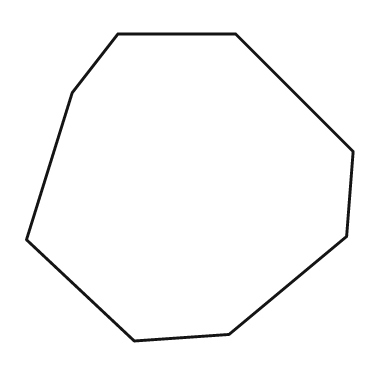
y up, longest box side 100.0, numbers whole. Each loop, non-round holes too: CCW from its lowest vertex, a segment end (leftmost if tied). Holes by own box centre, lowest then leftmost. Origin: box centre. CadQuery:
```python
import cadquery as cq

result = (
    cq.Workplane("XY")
    .moveTo(-17.0, -47.0)
    .lineTo(12.0, -45.0)
    .lineTo(48.0, -15.0)
    .lineTo(50.0, 11.0)
    .lineTo(14.0, 47.0)
    .lineTo(-22.0, 47.0)
    .lineTo(-36.0, 29.0)
    .lineTo(-50.0, -16.0)
    .close()
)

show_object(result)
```